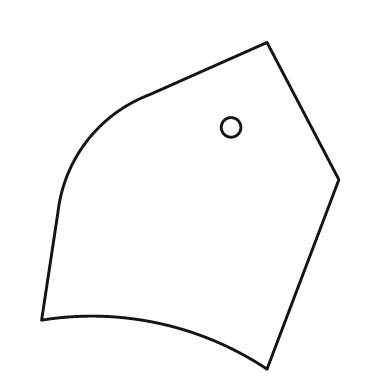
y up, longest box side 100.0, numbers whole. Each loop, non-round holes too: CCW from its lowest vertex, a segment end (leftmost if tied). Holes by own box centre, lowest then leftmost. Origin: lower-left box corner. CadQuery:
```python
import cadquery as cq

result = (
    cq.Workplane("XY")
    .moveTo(69.0, 0.0)
    .lineTo(91.0, 58.0)
    .lineTo(69.0, 100.0)
    .lineTo(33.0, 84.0)
    .threePointArc((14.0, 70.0), (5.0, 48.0))
    .lineTo(0.0, 15.0)
    .threePointArc((36.0, 14.0), (69.0, 0.0))
    .close()
    .moveTo(58.0, 74.0)
    .circle(3.0)
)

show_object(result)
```